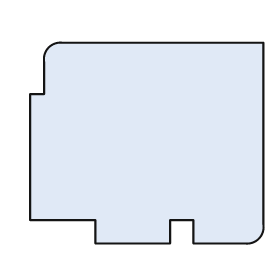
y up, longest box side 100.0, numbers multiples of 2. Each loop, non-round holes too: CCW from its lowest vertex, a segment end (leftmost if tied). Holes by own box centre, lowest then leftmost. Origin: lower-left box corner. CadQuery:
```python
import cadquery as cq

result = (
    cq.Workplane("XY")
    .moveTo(28.0, 0.0)
    .lineTo(60.0, 0.0)
    .lineTo(60.0, 10.0)
    .lineTo(70.0, 10.0)
    .lineTo(70.0, 0.0)
    .lineTo(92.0, 0.0)
    .threePointArc((98.0, 2.0), (100.0, 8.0))
    .lineTo(100.0, 86.0)
    .lineTo(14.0, 86.0)
    .threePointArc((8.0, 84.0), (6.0, 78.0))
    .lineTo(6.0, 64.0)
    .lineTo(0.0, 64.0)
    .lineTo(0.0, 10.0)
    .lineTo(28.0, 10.0)
    .close()
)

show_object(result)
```